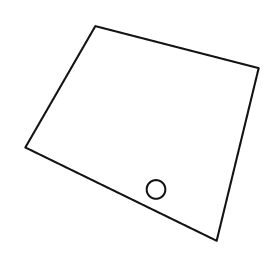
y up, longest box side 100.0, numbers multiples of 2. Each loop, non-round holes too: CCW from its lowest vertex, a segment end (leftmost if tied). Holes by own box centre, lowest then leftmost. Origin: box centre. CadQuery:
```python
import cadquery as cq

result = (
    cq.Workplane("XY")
    .moveTo(32.0, -46.0)
    .lineTo(50.0, 28.0)
    .lineTo(-20.0, 46.0)
    .lineTo(-50.0, -6.0)
    .close()
    .moveTo(6.0, -24.0)
    .circle(4.0)
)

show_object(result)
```